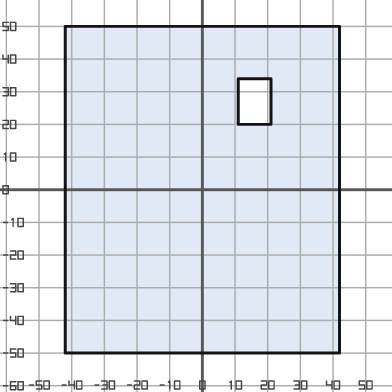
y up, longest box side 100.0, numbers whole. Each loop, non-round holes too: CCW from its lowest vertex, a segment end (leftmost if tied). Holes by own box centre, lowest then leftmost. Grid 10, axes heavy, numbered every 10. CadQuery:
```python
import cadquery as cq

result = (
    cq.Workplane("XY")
    .moveTo(-42.0, -50.0)
    .lineTo(42.0, -50.0)
    .lineTo(42.0, 50.0)
    .lineTo(-42.0, 50.0)
    .close()
    .moveTo(11.0, 20.0)
    .lineTo(21.0, 20.0)
    .lineTo(21.0, 34.0)
    .lineTo(11.0, 34.0)
    .close()
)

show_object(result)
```